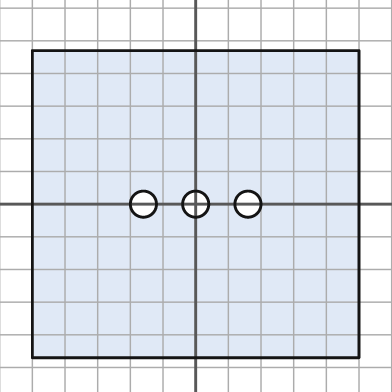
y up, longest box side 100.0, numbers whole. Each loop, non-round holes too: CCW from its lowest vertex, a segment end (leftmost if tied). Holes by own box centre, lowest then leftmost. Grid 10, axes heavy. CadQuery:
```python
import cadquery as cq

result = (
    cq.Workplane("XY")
    .moveTo(-50.0, -47.0)
    .lineTo(50.0, -47.0)
    .lineTo(50.0, 47.0)
    .lineTo(-50.0, 47.0)
    .close()
    .moveTo(-16.0, 0.0)
    .circle(4.0)
    .moveTo(0.0, 0.0)
    .circle(4.0)
    .moveTo(16.0, 0.0)
    .circle(4.0)
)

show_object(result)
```